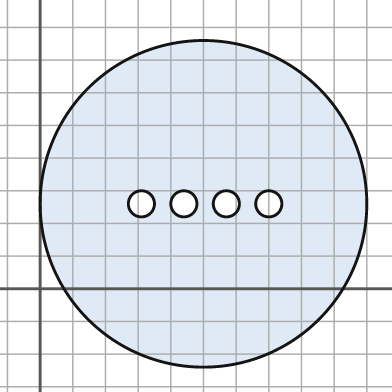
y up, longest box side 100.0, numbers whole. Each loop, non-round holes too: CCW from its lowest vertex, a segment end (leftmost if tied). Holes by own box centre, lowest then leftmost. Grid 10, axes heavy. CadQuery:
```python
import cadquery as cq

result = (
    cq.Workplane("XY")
    .moveTo(50.0, 26.0)
    .circle(50.0)
    .moveTo(31.0, 26.0)
    .circle(4.0)
    .moveTo(44.0, 26.0)
    .circle(4.0)
    .moveTo(57.0, 26.0)
    .circle(4.0)
    .moveTo(70.0, 26.0)
    .circle(4.0)
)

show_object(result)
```